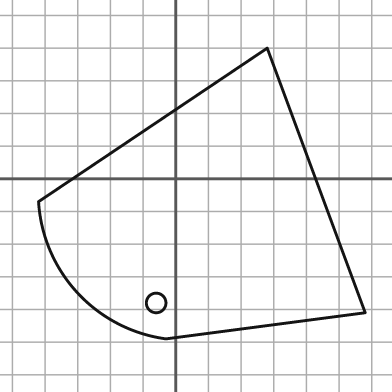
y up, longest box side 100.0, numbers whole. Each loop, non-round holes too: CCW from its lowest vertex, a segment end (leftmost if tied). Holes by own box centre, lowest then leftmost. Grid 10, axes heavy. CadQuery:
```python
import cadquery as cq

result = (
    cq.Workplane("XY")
    .moveTo(-3.0, -49.0)
    .lineTo(58.0, -41.0)
    .lineTo(28.0, 40.0)
    .lineTo(-42.0, -7.0)
    .threePointArc((-30.0, -35.0), (-3.0, -49.0))
    .close()
    .moveTo(-6.0, -38.0)
    .circle(3.0)
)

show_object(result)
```